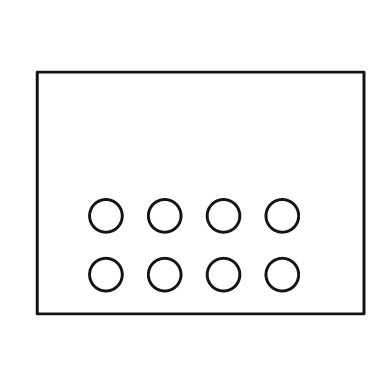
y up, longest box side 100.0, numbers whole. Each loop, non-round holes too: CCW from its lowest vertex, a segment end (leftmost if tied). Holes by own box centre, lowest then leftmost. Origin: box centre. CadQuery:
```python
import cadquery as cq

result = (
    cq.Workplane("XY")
    .moveTo(-50.0, -37.0)
    .lineTo(50.0, -37.0)
    .lineTo(50.0, 37.0)
    .lineTo(-50.0, 37.0)
    .close()
    .moveTo(-29.0, -25.0)
    .circle(5.0)
    .moveTo(-11.0, -25.0)
    .circle(5.0)
    .moveTo(7.0, -25.0)
    .circle(5.0)
    .moveTo(25.0, -25.0)
    .circle(5.0)
    .moveTo(-29.0, -7.0)
    .circle(5.0)
    .moveTo(-11.0, -7.0)
    .circle(5.0)
    .moveTo(7.0, -7.0)
    .circle(5.0)
    .moveTo(25.0, -7.0)
    .circle(5.0)
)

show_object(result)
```